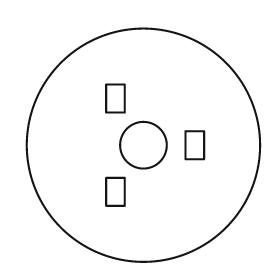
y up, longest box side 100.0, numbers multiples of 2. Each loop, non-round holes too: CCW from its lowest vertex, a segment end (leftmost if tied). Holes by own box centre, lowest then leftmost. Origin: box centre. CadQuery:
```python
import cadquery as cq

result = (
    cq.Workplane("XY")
    .moveTo(0.0, 0.0)
    .circle(50.0)
    .moveTo(-16.0, -26.0)
    .lineTo(-8.0, -26.0)
    .lineTo(-8.0, -14.0)
    .lineTo(-16.0, -14.0)
    .close()
    .moveTo(0.0, 0.0)
    .circle(10.0)
    .moveTo(18.0, -6.0)
    .lineTo(26.0, -6.0)
    .lineTo(26.0, 6.0)
    .lineTo(18.0, 6.0)
    .close()
    .moveTo(-16.0, 14.0)
    .lineTo(-8.0, 14.0)
    .lineTo(-8.0, 26.0)
    .lineTo(-16.0, 26.0)
    .close()
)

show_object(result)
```